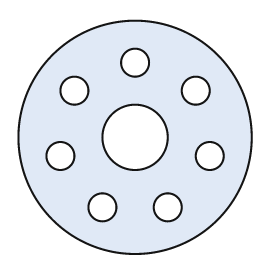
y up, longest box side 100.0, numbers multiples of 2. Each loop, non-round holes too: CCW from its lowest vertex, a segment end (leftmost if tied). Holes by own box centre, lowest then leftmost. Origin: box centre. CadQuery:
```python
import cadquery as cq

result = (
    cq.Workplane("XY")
    .moveTo(0.0, 0.0)
    .circle(50.0)
    .moveTo(-14.0, -30.0)
    .circle(6.0)
    .moveTo(14.0, -30.0)
    .circle(6.0)
    .moveTo(-32.0, -8.0)
    .circle(6.0)
    .moveTo(32.0, -8.0)
    .circle(6.0)
    .moveTo(0.0, 0.0)
    .circle(14.0)
    .moveTo(-26.0, 20.0)
    .circle(6.0)
    .moveTo(26.0, 20.0)
    .circle(6.0)
    .moveTo(0.0, 32.0)
    .circle(6.0)
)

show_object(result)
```